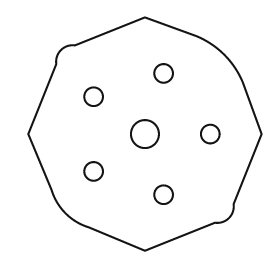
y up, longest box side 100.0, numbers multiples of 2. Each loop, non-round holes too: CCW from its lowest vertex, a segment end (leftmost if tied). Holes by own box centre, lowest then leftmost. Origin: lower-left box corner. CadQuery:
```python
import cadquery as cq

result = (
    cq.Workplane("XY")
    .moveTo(50.0, 0.0)
    .lineTo(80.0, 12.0)
    .threePointArc((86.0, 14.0), (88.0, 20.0))
    .lineTo(100.0, 50.0)
    .lineTo(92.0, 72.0)
    .threePointArc((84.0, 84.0), (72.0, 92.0))
    .lineTo(50.0, 100.0)
    .lineTo(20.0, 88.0)
    .threePointArc((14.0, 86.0), (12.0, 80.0))
    .lineTo(0.0, 50.0)
    .lineTo(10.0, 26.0)
    .threePointArc((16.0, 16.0), (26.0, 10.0))
    .close()
    .moveTo(58.0, 24.0)
    .circle(4.0)
    .moveTo(28.0, 34.0)
    .circle(4.0)
    .moveTo(50.0, 50.0)
    .circle(6.0)
    .moveTo(78.0, 50.0)
    .circle(4.0)
    .moveTo(28.0, 66.0)
    .circle(4.0)
    .moveTo(58.0, 76.0)
    .circle(4.0)
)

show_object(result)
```